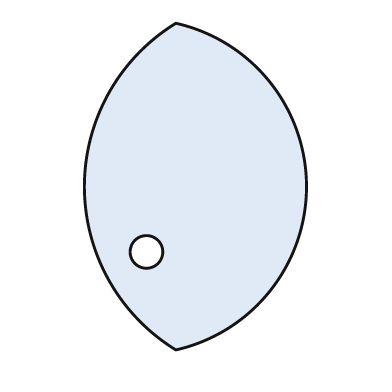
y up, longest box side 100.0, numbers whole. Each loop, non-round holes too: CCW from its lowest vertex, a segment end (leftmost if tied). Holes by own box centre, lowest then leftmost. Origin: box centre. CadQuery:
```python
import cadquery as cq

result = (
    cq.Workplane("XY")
    .moveTo(-6.0, -50.0)
    .threePointArc((34.0, 0.0), (-6.0, 50.0))
    .threePointArc((-34.0, 0.0), (-6.0, -50.0))
    .close()
    .moveTo(-15.0, -20.0)
    .circle(5.0)
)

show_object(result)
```